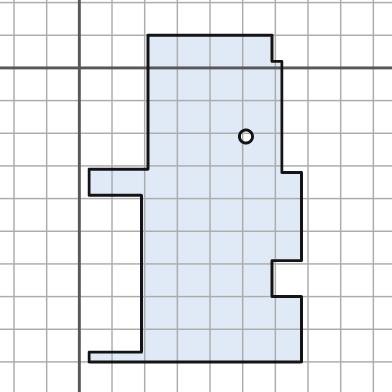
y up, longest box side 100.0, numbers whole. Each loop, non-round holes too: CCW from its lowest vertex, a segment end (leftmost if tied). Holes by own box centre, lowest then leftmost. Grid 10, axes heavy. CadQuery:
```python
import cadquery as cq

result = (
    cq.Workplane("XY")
    .moveTo(3.0, -90.0)
    .lineTo(68.0, -90.0)
    .lineTo(68.0, -70.0)
    .lineTo(59.0, -70.0)
    .lineTo(59.0, -59.0)
    .lineTo(68.0, -59.0)
    .lineTo(68.0, -32.0)
    .lineTo(62.0, -32.0)
    .lineTo(62.0, 2.0)
    .lineTo(59.0, 2.0)
    .lineTo(59.0, 10.0)
    .lineTo(21.0, 10.0)
    .lineTo(21.0, -31.0)
    .lineTo(3.0, -31.0)
    .lineTo(3.0, -39.0)
    .lineTo(19.0, -39.0)
    .lineTo(19.0, -87.0)
    .lineTo(3.0, -87.0)
    .close()
    .moveTo(51.0, -21.0)
    .circle(2.0)
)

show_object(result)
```